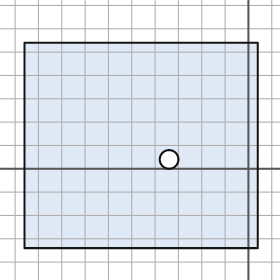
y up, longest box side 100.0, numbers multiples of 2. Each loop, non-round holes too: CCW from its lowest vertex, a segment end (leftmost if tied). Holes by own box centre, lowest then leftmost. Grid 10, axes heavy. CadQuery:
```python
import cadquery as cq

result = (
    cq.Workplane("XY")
    .moveTo(-96.0, -34.0)
    .lineTo(4.0, -34.0)
    .lineTo(4.0, 54.0)
    .lineTo(-96.0, 54.0)
    .close()
    .moveTo(-34.0, 4.0)
    .circle(4.0)
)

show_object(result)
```